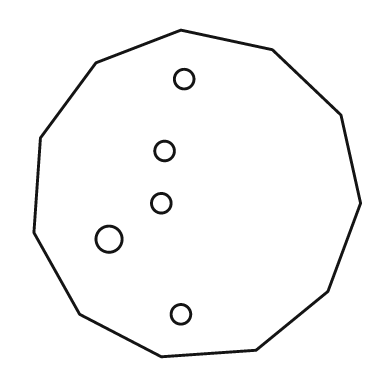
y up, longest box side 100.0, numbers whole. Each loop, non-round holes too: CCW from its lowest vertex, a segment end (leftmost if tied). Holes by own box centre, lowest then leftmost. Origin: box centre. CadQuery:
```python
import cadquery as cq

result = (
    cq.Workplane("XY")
    .moveTo(-11.0, -50.0)
    .lineTo(18.0, -48.0)
    .lineTo(40.0, -30.0)
    .lineTo(50.0, -3.0)
    .lineTo(44.0, 24.0)
    .lineTo(23.0, 44.0)
    .lineTo(-5.0, 50.0)
    .lineTo(-31.0, 40.0)
    .lineTo(-48.0, 17.0)
    .lineTo(-50.0, -12.0)
    .lineTo(-36.0, -37.0)
    .close()
    .moveTo(-5.0, -37.0)
    .circle(3.0)
    .moveTo(-27.0, -14.0)
    .circle(4.0)
    .moveTo(-11.0, -3.0)
    .circle(3.0)
    .moveTo(-10.0, 13.0)
    .circle(3.0)
    .moveTo(-4.0, 35.0)
    .circle(3.0)
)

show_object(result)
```